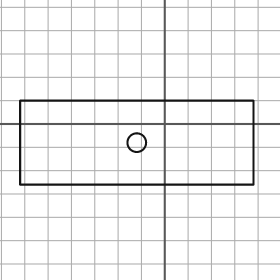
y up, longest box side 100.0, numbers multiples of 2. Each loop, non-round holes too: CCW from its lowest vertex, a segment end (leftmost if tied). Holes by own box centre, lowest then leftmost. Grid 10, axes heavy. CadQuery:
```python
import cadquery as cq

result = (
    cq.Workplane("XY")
    .moveTo(-62.0, -26.0)
    .lineTo(38.0, -26.0)
    .lineTo(38.0, 10.0)
    .lineTo(-62.0, 10.0)
    .close()
    .moveTo(-12.0, -8.0)
    .circle(4.0)
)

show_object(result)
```